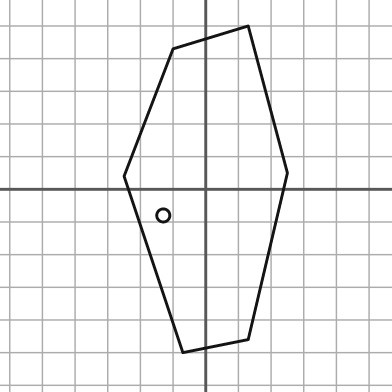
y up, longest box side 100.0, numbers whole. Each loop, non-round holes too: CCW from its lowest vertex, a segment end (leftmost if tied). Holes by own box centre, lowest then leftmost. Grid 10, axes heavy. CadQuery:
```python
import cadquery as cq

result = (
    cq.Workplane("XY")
    .moveTo(-7.0, -50.0)
    .lineTo(13.0, -46.0)
    .lineTo(25.0, 5.0)
    .lineTo(13.0, 50.0)
    .lineTo(-10.0, 43.0)
    .lineTo(-25.0, 4.0)
    .close()
    .moveTo(-13.0, -8.0)
    .circle(2.0)
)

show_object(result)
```